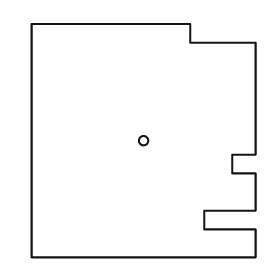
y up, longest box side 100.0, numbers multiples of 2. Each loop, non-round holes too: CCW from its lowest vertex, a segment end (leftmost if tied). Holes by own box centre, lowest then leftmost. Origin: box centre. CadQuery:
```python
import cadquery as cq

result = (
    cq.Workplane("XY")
    .moveTo(-48.0, -50.0)
    .lineTo(48.0, -50.0)
    .lineTo(48.0, -38.0)
    .lineTo(26.0, -38.0)
    .lineTo(26.0, -30.0)
    .lineTo(48.0, -30.0)
    .lineTo(48.0, -14.0)
    .lineTo(38.0, -14.0)
    .lineTo(38.0, -6.0)
    .lineTo(48.0, -6.0)
    .lineTo(48.0, 42.0)
    .lineTo(20.0, 42.0)
    .lineTo(20.0, 50.0)
    .lineTo(-48.0, 50.0)
    .close()
    .moveTo(0.0, 0.0)
    .circle(2.0)
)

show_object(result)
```